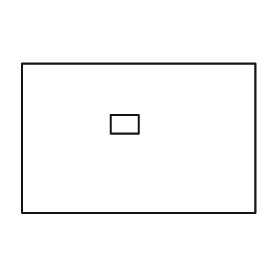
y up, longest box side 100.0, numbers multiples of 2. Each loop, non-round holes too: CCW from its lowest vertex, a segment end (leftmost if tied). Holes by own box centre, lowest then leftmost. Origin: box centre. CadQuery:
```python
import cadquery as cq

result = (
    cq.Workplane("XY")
    .moveTo(-50.0, -32.0)
    .lineTo(50.0, -32.0)
    .lineTo(50.0, 32.0)
    .lineTo(-50.0, 32.0)
    .close()
    .moveTo(-12.0, 2.0)
    .lineTo(0.0, 2.0)
    .lineTo(0.0, 10.0)
    .lineTo(-12.0, 10.0)
    .close()
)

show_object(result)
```